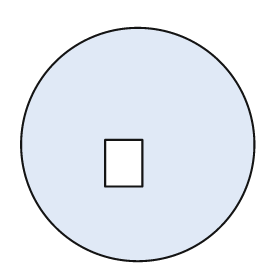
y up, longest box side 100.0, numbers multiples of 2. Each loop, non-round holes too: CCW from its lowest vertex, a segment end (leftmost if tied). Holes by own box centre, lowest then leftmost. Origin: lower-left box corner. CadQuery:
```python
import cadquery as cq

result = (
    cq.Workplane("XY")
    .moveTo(50.0, 50.0)
    .circle(50.0)
    .moveTo(36.0, 32.0)
    .lineTo(52.0, 32.0)
    .lineTo(52.0, 52.0)
    .lineTo(36.0, 52.0)
    .close()
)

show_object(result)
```